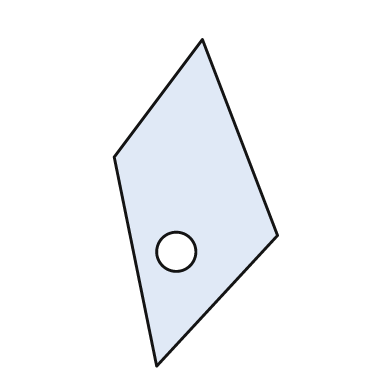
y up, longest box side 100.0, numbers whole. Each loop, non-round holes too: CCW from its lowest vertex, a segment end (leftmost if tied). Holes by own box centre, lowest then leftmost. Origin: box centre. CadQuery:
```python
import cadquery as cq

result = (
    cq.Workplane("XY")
    .moveTo(-12.0, -50.0)
    .lineTo(25.0, -10.0)
    .lineTo(2.0, 50.0)
    .lineTo(-25.0, 14.0)
    .close()
    .moveTo(-6.0, -15.0)
    .circle(6.0)
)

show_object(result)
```